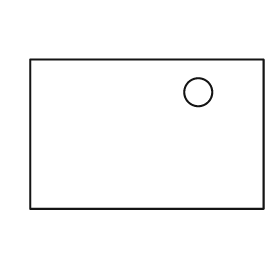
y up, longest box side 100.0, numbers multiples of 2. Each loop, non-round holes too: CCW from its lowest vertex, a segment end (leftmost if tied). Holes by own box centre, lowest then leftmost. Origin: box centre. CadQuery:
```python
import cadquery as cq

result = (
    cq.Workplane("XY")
    .moveTo(-50.0, -32.0)
    .lineTo(50.0, -32.0)
    .lineTo(50.0, 32.0)
    .lineTo(-50.0, 32.0)
    .close()
    .moveTo(22.0, 18.0)
    .circle(6.0)
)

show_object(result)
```